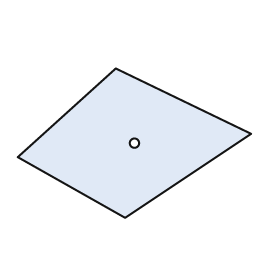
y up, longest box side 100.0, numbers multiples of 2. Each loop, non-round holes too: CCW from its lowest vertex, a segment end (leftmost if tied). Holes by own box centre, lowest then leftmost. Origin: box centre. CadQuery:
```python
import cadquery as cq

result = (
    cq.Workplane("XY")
    .moveTo(-4.0, -32.0)
    .lineTo(50.0, 4.0)
    .lineTo(-8.0, 32.0)
    .lineTo(-50.0, -6.0)
    .close()
    .moveTo(0.0, 0.0)
    .circle(2.0)
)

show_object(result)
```